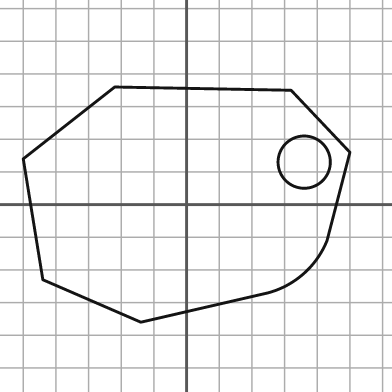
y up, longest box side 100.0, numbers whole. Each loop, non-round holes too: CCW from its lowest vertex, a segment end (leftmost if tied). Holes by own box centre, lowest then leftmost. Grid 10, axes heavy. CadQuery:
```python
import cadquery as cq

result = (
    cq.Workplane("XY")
    .moveTo(-14.0, -36.0)
    .lineTo(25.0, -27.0)
    .threePointArc((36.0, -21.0), (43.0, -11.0))
    .lineTo(50.0, 16.0)
    .lineTo(32.0, 35.0)
    .lineTo(-22.0, 36.0)
    .lineTo(-50.0, 14.0)
    .lineTo(-44.0, -23.0)
    .close()
    .moveTo(36.0, 13.0)
    .circle(8.0)
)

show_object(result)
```